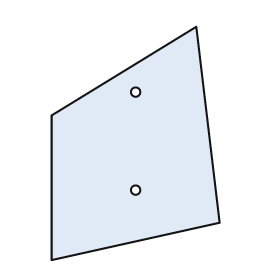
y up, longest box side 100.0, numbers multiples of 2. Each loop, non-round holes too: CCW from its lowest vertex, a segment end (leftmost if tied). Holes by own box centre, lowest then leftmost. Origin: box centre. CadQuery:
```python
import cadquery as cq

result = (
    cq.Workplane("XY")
    .moveTo(-36.0, -50.0)
    .lineTo(36.0, -34.0)
    .lineTo(26.0, 50.0)
    .lineTo(-36.0, 12.0)
    .close()
    .moveTo(0.0, -20.0)
    .circle(2.0)
    .moveTo(0.0, 22.0)
    .circle(2.0)
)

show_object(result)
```